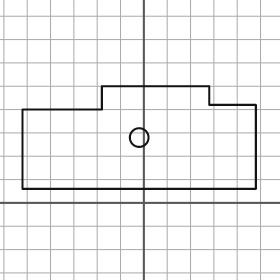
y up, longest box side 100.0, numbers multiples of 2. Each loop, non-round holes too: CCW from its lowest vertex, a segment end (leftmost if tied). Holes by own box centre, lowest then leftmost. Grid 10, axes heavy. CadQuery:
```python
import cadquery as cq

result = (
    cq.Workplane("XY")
    .moveTo(-52.0, 6.0)
    .lineTo(48.0, 6.0)
    .lineTo(48.0, 42.0)
    .lineTo(28.0, 42.0)
    .lineTo(28.0, 50.0)
    .lineTo(-18.0, 50.0)
    .lineTo(-18.0, 40.0)
    .lineTo(-52.0, 40.0)
    .close()
    .moveTo(-2.0, 28.0)
    .circle(4.0)
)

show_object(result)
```